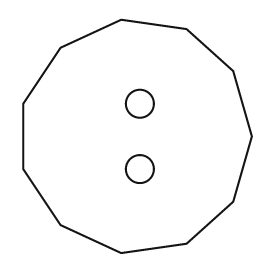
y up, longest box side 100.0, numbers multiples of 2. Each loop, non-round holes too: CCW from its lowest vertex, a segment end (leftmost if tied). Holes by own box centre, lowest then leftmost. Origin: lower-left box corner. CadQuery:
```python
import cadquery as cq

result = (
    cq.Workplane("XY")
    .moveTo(42.0, 0.0)
    .lineTo(70.0, 4.0)
    .lineTo(90.0, 22.0)
    .lineTo(98.0, 50.0)
    .lineTo(90.0, 78.0)
    .lineTo(70.0, 96.0)
    .lineTo(42.0, 100.0)
    .lineTo(16.0, 88.0)
    .lineTo(0.0, 64.0)
    .lineTo(0.0, 36.0)
    .lineTo(16.0, 12.0)
    .close()
    .moveTo(50.0, 36.0)
    .circle(6.0)
    .moveTo(50.0, 64.0)
    .circle(6.0)
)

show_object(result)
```